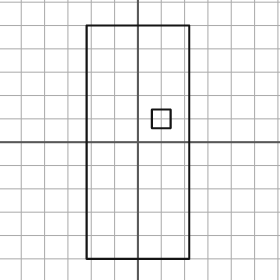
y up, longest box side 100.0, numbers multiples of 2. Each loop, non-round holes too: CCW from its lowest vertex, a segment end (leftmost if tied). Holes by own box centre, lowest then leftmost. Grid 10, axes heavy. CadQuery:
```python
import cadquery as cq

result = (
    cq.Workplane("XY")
    .moveTo(-22.0, -50.0)
    .lineTo(22.0, -50.0)
    .lineTo(22.0, 50.0)
    .lineTo(-22.0, 50.0)
    .close()
    .moveTo(6.0, 6.0)
    .lineTo(14.0, 6.0)
    .lineTo(14.0, 14.0)
    .lineTo(6.0, 14.0)
    .close()
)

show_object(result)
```